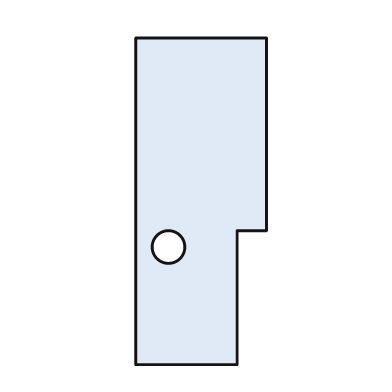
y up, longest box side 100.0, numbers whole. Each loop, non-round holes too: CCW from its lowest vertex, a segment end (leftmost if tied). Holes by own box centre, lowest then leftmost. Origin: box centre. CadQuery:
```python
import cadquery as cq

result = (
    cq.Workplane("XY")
    .moveTo(-20.0, -50.0)
    .lineTo(11.0, -50.0)
    .lineTo(11.0, -9.0)
    .lineTo(20.0, -9.0)
    .lineTo(20.0, 50.0)
    .lineTo(-20.0, 50.0)
    .close()
    .moveTo(-10.0, -14.0)
    .circle(5.0)
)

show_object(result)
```